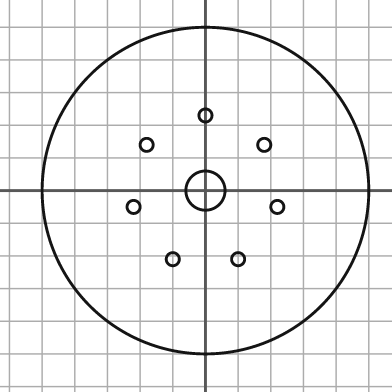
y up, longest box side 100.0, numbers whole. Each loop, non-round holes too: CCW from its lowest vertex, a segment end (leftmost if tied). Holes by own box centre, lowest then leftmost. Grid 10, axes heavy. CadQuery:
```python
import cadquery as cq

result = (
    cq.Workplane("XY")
    .moveTo(0.0, 0.0)
    .circle(50.0)
    .moveTo(-10.0, -21.0)
    .circle(2.0)
    .moveTo(10.0, -21.0)
    .circle(2.0)
    .moveTo(-22.0, -5.0)
    .circle(2.0)
    .moveTo(22.0, -5.0)
    .circle(2.0)
    .moveTo(0.0, 0.0)
    .circle(6.0)
    .moveTo(-18.0, 14.0)
    .circle(2.0)
    .moveTo(18.0, 14.0)
    .circle(2.0)
    .moveTo(0.0, 23.0)
    .circle(2.0)
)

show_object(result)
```